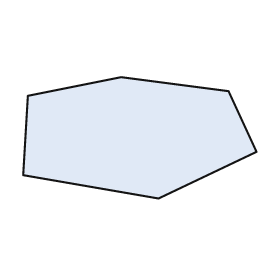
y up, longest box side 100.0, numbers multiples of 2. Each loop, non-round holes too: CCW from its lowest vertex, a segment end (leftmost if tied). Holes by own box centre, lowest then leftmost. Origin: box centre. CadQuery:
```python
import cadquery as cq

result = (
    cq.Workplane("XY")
    .moveTo(8.0, -26.0)
    .lineTo(50.0, -6.0)
    .lineTo(38.0, 20.0)
    .lineTo(-8.0, 26.0)
    .lineTo(-48.0, 18.0)
    .lineTo(-50.0, -16.0)
    .close()
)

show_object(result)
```